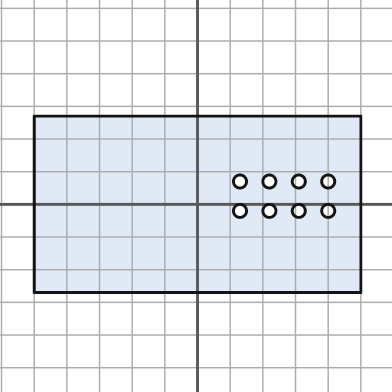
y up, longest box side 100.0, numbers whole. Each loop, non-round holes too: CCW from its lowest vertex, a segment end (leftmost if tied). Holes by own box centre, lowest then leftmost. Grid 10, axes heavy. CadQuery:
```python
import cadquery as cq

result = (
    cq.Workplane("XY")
    .moveTo(-50.0, -27.0)
    .lineTo(50.0, -27.0)
    .lineTo(50.0, 27.0)
    .lineTo(-50.0, 27.0)
    .close()
    .moveTo(13.0, -2.0)
    .circle(2.0)
    .moveTo(22.0, -2.0)
    .circle(2.0)
    .moveTo(31.0, -2.0)
    .circle(2.0)
    .moveTo(40.0, -2.0)
    .circle(2.0)
    .moveTo(13.0, 7.0)
    .circle(2.0)
    .moveTo(22.0, 7.0)
    .circle(2.0)
    .moveTo(31.0, 7.0)
    .circle(2.0)
    .moveTo(40.0, 7.0)
    .circle(2.0)
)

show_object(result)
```